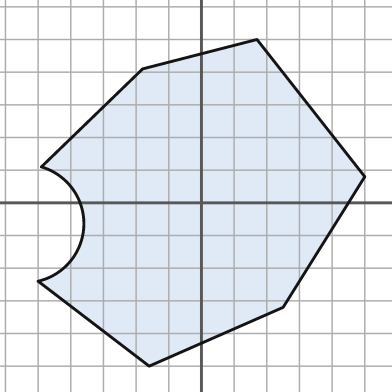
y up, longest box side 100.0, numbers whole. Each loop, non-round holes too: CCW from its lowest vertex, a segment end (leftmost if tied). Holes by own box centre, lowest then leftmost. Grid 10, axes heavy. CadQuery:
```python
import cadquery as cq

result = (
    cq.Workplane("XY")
    .moveTo(-16.0, -50.0)
    .lineTo(25.0, -32.0)
    .lineTo(50.0, 8.0)
    .lineTo(17.0, 50.0)
    .lineTo(-18.0, 41.0)
    .lineTo(-49.0, 11.0)
    .threePointArc((-36.0, -7.0), (-50.0, -24.0))
    .close()
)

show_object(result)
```